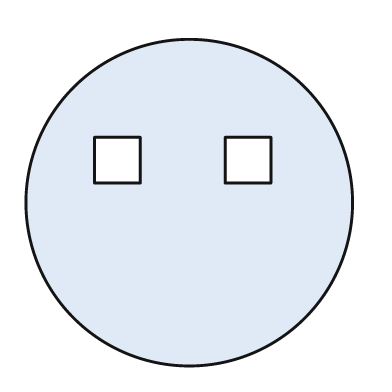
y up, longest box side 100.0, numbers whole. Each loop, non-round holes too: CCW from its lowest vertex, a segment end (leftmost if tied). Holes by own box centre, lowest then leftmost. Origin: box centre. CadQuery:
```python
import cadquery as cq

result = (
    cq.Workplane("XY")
    .moveTo(0.0, 0.0)
    .circle(50.0)
    .moveTo(-29.0, 6.0)
    .lineTo(-15.0, 6.0)
    .lineTo(-15.0, 20.0)
    .lineTo(-29.0, 20.0)
    .close()
    .moveTo(11.0, 6.0)
    .lineTo(25.0, 6.0)
    .lineTo(25.0, 20.0)
    .lineTo(11.0, 20.0)
    .close()
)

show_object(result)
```